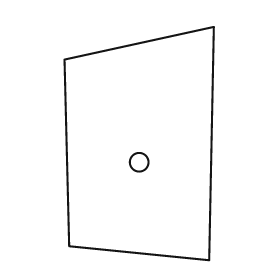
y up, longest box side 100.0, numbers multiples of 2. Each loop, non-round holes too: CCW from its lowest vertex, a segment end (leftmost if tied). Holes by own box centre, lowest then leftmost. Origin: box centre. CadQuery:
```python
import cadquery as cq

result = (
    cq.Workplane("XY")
    .moveTo(30.0, -50.0)
    .lineTo(32.0, 50.0)
    .lineTo(-32.0, 36.0)
    .lineTo(-30.0, -44.0)
    .close()
    .moveTo(0.0, -8.0)
    .circle(4.0)
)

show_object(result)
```